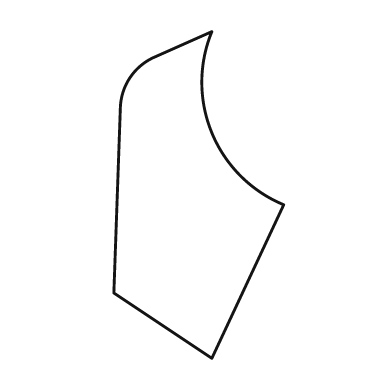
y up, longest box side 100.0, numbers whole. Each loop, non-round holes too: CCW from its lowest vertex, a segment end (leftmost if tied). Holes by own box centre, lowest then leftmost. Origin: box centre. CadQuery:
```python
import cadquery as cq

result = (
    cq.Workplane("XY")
    .moveTo(4.0, -50.0)
    .lineTo(26.0, -3.0)
    .threePointArc((4.0, 19.0), (4.0, 50.0))
    .lineTo(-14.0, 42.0)
    .threePointArc((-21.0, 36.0), (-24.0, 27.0))
    .lineTo(-26.0, -30.0)
    .close()
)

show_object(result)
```